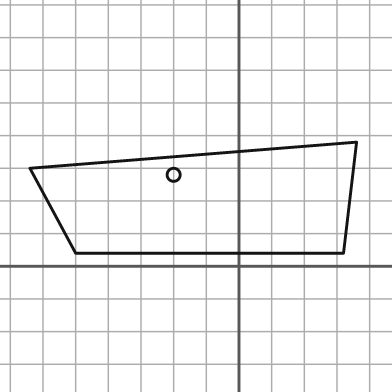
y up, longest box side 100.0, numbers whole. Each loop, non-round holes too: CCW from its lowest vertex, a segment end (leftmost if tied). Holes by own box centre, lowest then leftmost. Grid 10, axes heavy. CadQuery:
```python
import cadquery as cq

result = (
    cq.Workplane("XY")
    .moveTo(-50.0, 4.0)
    .lineTo(32.0, 4.0)
    .lineTo(36.0, 38.0)
    .lineTo(-64.0, 30.0)
    .close()
    .moveTo(-20.0, 28.0)
    .circle(2.0)
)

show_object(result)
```